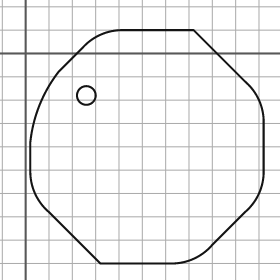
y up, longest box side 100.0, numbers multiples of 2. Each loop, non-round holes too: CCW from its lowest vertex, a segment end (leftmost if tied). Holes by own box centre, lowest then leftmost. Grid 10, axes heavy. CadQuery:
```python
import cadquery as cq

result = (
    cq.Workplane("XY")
    .moveTo(32.0, -90.0)
    .lineTo(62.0, -90.0)
    .threePointArc((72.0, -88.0), (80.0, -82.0))
    .lineTo(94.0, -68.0)
    .threePointArc((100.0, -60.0), (102.0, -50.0))
    .lineTo(102.0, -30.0)
    .threePointArc((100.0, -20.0), (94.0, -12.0))
    .lineTo(72.0, 10.0)
    .lineTo(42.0, 10.0)
    .threePointArc((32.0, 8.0), (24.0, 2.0))
    .lineTo(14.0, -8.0)
    .threePointArc((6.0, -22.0), (2.0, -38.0))
    .lineTo(2.0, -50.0)
    .threePointArc((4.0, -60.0), (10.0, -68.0))
    .close()
    .moveTo(26.0, -18.0)
    .circle(4.0)
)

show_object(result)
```